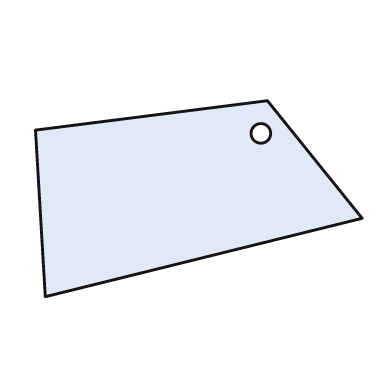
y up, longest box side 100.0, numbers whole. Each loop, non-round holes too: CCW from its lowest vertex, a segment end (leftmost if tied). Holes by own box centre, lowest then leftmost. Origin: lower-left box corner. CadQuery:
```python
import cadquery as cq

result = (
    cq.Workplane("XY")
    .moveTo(3.0, 0.0)
    .lineTo(100.0, 24.0)
    .lineTo(71.0, 60.0)
    .lineTo(0.0, 51.0)
    .close()
    .moveTo(69.0, 50.0)
    .circle(3.0)
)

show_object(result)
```